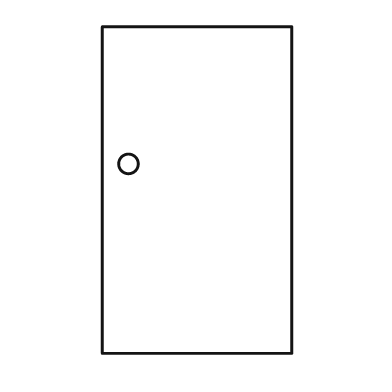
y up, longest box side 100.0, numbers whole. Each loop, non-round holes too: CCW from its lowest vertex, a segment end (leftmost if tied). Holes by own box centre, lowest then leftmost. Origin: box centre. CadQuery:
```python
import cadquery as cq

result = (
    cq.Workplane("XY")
    .moveTo(-29.0, -50.0)
    .lineTo(29.0, -50.0)
    .lineTo(29.0, 50.0)
    .lineTo(-29.0, 50.0)
    .close()
    .moveTo(-21.0, 8.0)
    .circle(3.0)
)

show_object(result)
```